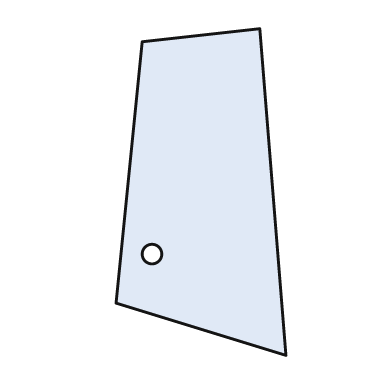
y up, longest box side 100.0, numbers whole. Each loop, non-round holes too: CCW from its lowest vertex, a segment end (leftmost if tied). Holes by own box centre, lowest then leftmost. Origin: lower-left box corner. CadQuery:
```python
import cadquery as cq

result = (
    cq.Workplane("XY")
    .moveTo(52.0, 0.0)
    .lineTo(44.0, 100.0)
    .lineTo(8.0, 96.0)
    .lineTo(0.0, 16.0)
    .close()
    .moveTo(11.0, 31.0)
    .circle(3.0)
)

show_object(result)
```